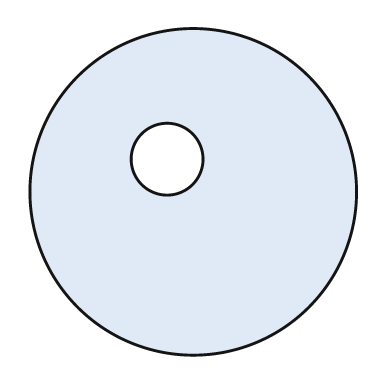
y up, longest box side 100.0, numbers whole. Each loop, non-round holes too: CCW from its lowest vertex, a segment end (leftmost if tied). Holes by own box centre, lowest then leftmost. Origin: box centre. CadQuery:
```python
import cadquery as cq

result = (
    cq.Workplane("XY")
    .moveTo(0.0, 0.0)
    .circle(50.0)
    .moveTo(-8.0, 10.0)
    .circle(11.0)
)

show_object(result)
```